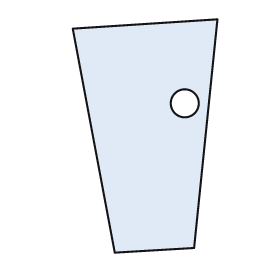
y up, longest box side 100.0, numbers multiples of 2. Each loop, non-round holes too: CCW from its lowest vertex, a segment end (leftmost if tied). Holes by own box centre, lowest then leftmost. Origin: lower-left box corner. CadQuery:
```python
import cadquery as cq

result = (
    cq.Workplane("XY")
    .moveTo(18.0, 0.0)
    .lineTo(52.0, 2.0)
    .lineTo(62.0, 100.0)
    .lineTo(0.0, 96.0)
    .close()
    .moveTo(48.0, 64.0)
    .circle(6.0)
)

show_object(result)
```